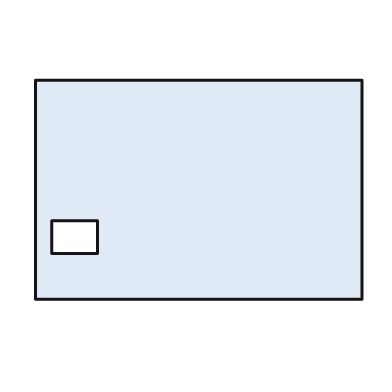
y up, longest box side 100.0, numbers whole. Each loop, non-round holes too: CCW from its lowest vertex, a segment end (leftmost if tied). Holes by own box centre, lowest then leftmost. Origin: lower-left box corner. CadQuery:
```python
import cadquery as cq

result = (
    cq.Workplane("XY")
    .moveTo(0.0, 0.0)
    .lineTo(100.0, 0.0)
    .lineTo(100.0, 67.0)
    .lineTo(0.0, 67.0)
    .close()
    .moveTo(5.0, 14.0)
    .lineTo(19.0, 14.0)
    .lineTo(19.0, 24.0)
    .lineTo(5.0, 24.0)
    .close()
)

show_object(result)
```